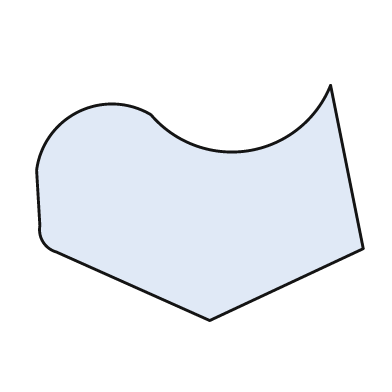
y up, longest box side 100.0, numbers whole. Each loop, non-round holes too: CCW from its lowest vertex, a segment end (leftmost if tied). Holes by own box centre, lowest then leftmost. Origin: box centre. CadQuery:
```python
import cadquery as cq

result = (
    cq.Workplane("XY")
    .moveTo(3.0, -36.0)
    .lineTo(50.0, -14.0)
    .lineTo(40.0, 36.0)
    .threePointArc((15.0, 16.0), (-15.0, 27.0))
    .threePointArc((-37.0, 28.0), (-50.0, 10.0))
    .lineTo(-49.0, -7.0)
    .threePointArc((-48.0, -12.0), (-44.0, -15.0))
    .close()
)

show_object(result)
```